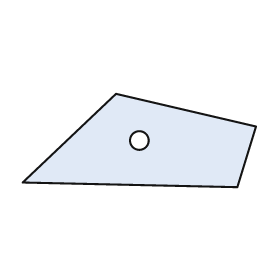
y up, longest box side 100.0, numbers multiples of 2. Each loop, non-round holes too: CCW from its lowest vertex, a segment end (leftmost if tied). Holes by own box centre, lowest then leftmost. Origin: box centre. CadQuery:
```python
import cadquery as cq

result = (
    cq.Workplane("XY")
    .moveTo(42.0, -20.0)
    .lineTo(50.0, 6.0)
    .lineTo(-10.0, 20.0)
    .lineTo(-50.0, -18.0)
    .close()
    .moveTo(0.0, 0.0)
    .circle(4.0)
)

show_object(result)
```